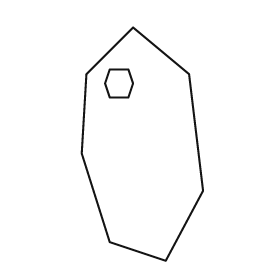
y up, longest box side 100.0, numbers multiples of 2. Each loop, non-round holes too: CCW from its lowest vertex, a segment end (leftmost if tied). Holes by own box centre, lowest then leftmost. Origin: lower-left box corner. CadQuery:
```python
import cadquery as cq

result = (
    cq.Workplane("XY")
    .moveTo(36.0, 0.0)
    .lineTo(52.0, 30.0)
    .lineTo(46.0, 80.0)
    .lineTo(22.0, 100.0)
    .lineTo(2.0, 80.0)
    .lineTo(0.0, 46.0)
    .lineTo(12.0, 8.0)
    .close()
    .moveTo(12.0, 70.0)
    .lineTo(20.0, 70.0)
    .lineTo(22.0, 76.0)
    .lineTo(20.0, 82.0)
    .lineTo(12.0, 82.0)
    .lineTo(10.0, 76.0)
    .close()
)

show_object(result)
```